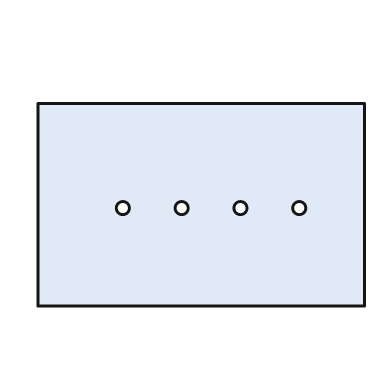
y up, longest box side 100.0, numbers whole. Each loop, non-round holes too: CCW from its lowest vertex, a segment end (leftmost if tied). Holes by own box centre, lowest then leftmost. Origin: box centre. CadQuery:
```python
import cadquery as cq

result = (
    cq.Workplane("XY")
    .moveTo(-50.0, -31.0)
    .lineTo(50.0, -31.0)
    .lineTo(50.0, 31.0)
    .lineTo(-50.0, 31.0)
    .close()
    .moveTo(-24.0, -1.0)
    .circle(2.0)
    .moveTo(-6.0, -1.0)
    .circle(2.0)
    .moveTo(12.0, -1.0)
    .circle(2.0)
    .moveTo(30.0, -1.0)
    .circle(2.0)
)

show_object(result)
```